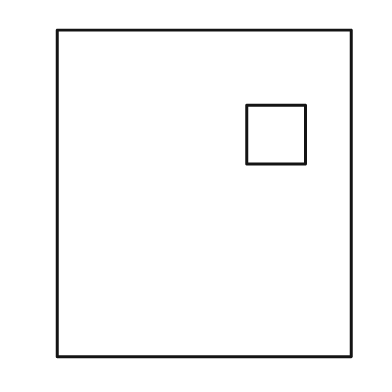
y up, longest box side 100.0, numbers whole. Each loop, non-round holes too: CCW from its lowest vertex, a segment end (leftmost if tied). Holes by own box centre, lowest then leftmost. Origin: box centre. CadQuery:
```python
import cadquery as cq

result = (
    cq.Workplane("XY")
    .moveTo(-45.0, -50.0)
    .lineTo(45.0, -50.0)
    .lineTo(45.0, 50.0)
    .lineTo(-45.0, 50.0)
    .close()
    .moveTo(13.0, 9.0)
    .lineTo(31.0, 9.0)
    .lineTo(31.0, 27.0)
    .lineTo(13.0, 27.0)
    .close()
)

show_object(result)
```